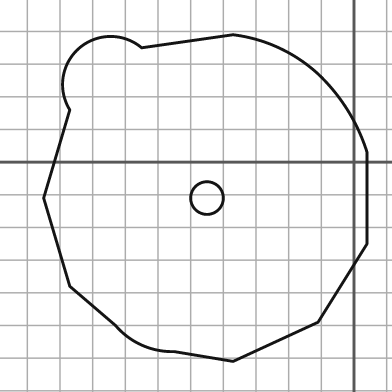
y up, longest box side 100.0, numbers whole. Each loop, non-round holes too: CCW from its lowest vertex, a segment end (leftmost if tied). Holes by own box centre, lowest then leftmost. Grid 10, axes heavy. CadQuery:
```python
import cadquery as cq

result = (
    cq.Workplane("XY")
    .moveTo(-37.0, -61.0)
    .lineTo(-11.0, -49.0)
    .lineTo(4.0, -25.0)
    .lineTo(4.0, 3.0)
    .threePointArc((-2.0, 16.0), (-11.0, 27.0))
    .threePointArc((-23.0, 35.0), (-37.0, 39.0))
    .lineTo(-65.0, 35.0)
    .threePointArc((-84.0, 35.0), (-87.0, 16.0))
    .lineTo(-95.0, -11.0)
    .lineTo(-87.0, -38.0)
    .lineTo(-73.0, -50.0)
    .threePointArc((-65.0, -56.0), (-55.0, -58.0))
    .close()
    .moveTo(-45.0, -11.0)
    .circle(5.0)
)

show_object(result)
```